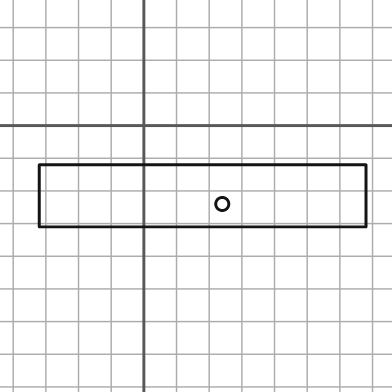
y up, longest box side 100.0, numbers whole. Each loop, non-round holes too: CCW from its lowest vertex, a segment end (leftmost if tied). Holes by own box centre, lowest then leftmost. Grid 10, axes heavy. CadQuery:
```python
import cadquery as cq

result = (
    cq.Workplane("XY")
    .moveTo(-32.0, -31.0)
    .lineTo(68.0, -31.0)
    .lineTo(68.0, -12.0)
    .lineTo(-32.0, -12.0)
    .close()
    .moveTo(24.0, -24.0)
    .circle(2.0)
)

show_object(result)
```